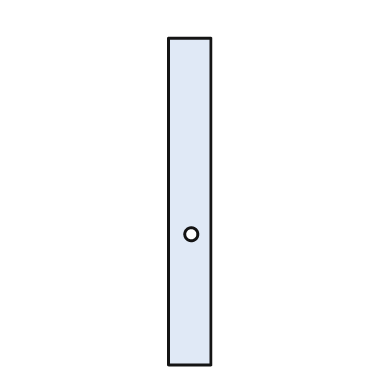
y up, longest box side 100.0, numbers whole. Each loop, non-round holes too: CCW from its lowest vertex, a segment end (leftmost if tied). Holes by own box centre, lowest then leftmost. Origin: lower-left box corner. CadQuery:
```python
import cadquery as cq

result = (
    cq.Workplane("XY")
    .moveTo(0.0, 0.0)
    .lineTo(13.0, 0.0)
    .lineTo(13.0, 100.0)
    .lineTo(0.0, 100.0)
    .close()
    .moveTo(7.0, 40.0)
    .circle(2.0)
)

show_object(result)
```